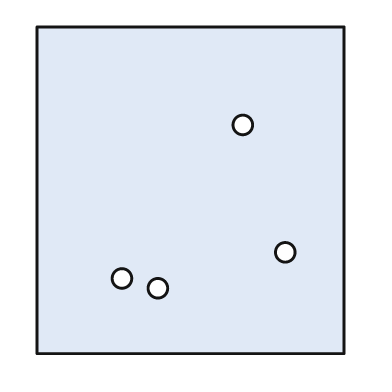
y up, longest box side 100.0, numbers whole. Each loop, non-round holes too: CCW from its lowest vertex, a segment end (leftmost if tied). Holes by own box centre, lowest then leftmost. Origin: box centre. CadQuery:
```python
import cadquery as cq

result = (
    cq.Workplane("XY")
    .moveTo(-47.0, -50.0)
    .lineTo(47.0, -50.0)
    .lineTo(47.0, 50.0)
    .lineTo(-47.0, 50.0)
    .close()
    .moveTo(-10.0, -30.0)
    .circle(3.0)
    .moveTo(-21.0, -27.0)
    .circle(3.0)
    .moveTo(29.0, -19.0)
    .circle(3.0)
    .moveTo(16.0, 20.0)
    .circle(3.0)
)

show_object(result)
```